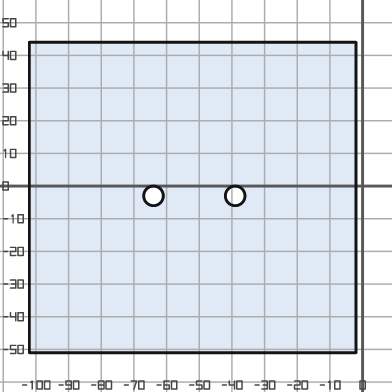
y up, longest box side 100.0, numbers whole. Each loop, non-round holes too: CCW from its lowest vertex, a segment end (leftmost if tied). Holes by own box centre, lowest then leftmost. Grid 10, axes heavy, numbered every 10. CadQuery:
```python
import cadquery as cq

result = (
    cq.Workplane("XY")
    .moveTo(-102.0, -51.0)
    .lineTo(-2.0, -51.0)
    .lineTo(-2.0, 44.0)
    .lineTo(-102.0, 44.0)
    .close()
    .moveTo(-64.0, -3.0)
    .circle(3.0)
    .moveTo(-39.0, -3.0)
    .circle(3.0)
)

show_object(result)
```